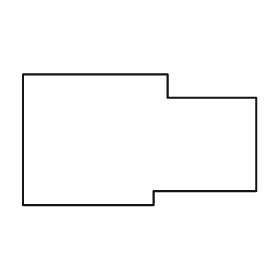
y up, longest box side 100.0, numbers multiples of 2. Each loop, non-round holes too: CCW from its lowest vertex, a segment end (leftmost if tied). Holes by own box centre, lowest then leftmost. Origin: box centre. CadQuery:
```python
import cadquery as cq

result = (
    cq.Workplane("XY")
    .moveTo(-50.0, -28.0)
    .lineTo(6.0, -28.0)
    .lineTo(6.0, -22.0)
    .lineTo(50.0, -22.0)
    .lineTo(50.0, 18.0)
    .lineTo(12.0, 18.0)
    .lineTo(12.0, 28.0)
    .lineTo(-50.0, 28.0)
    .close()
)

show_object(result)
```